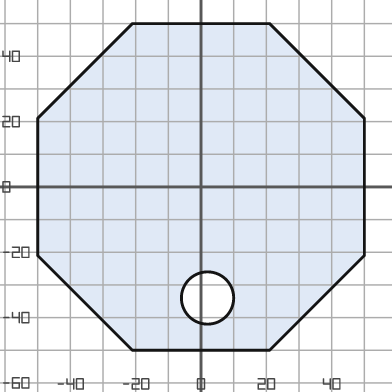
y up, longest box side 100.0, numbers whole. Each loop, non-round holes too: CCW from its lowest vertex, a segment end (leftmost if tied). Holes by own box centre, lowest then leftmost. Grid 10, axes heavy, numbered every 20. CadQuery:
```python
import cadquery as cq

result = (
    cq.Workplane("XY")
    .moveTo(-21.0, -50.0)
    .lineTo(21.0, -50.0)
    .lineTo(50.0, -21.0)
    .lineTo(50.0, 21.0)
    .lineTo(21.0, 50.0)
    .lineTo(-21.0, 50.0)
    .lineTo(-50.0, 21.0)
    .lineTo(-50.0, -21.0)
    .close()
    .moveTo(2.0, -34.0)
    .circle(8.0)
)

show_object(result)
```